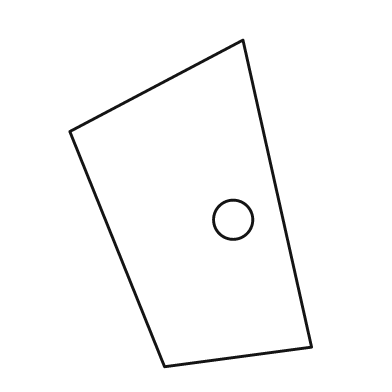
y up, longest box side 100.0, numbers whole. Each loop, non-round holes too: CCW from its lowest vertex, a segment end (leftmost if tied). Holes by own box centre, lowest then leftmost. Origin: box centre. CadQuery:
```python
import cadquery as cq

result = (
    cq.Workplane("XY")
    .moveTo(-8.0, -50.0)
    .lineTo(37.0, -44.0)
    .lineTo(16.0, 50.0)
    .lineTo(-37.0, 22.0)
    .close()
    .moveTo(13.0, -5.0)
    .circle(6.0)
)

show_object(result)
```